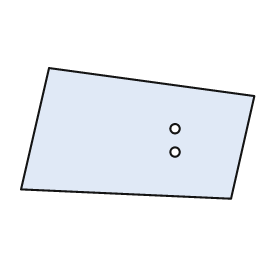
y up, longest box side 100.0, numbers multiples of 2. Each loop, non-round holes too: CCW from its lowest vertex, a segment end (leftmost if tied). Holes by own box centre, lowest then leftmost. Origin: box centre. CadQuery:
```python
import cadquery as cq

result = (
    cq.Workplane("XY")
    .moveTo(40.0, -28.0)
    .lineTo(50.0, 16.0)
    .lineTo(-38.0, 28.0)
    .lineTo(-50.0, -24.0)
    .close()
    .moveTo(16.0, -8.0)
    .circle(2.0)
    .moveTo(16.0, 2.0)
    .circle(2.0)
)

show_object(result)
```